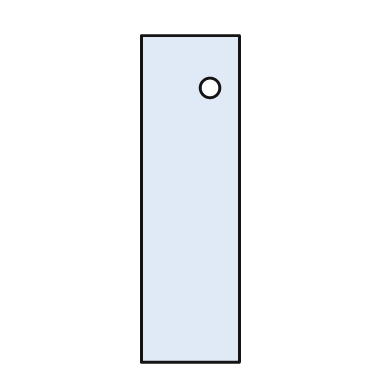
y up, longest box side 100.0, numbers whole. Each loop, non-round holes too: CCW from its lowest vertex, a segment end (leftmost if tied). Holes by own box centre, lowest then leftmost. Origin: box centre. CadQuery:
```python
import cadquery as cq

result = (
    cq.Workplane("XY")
    .moveTo(-15.0, -50.0)
    .lineTo(15.0, -50.0)
    .lineTo(15.0, 50.0)
    .lineTo(-15.0, 50.0)
    .close()
    .moveTo(6.0, 34.0)
    .circle(3.0)
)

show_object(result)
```